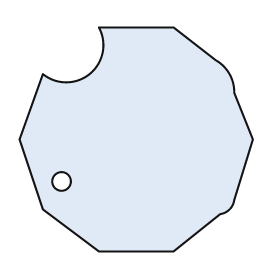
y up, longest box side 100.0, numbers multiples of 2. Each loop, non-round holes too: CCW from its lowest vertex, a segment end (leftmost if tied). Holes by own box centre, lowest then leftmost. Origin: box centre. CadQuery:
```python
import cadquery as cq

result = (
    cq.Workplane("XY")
    .moveTo(-16.0, -48.0)
    .lineTo(16.0, -48.0)
    .lineTo(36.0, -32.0)
    .threePointArc((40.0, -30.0), (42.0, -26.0))
    .lineTo(50.0, 0.0)
    .lineTo(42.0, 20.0)
    .threePointArc((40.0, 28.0), (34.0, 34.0))
    .lineTo(16.0, 48.0)
    .lineTo(-16.0, 48.0)
    .threePointArc((-20.0, 28.0), (-40.0, 28.0))
    .lineTo(-50.0, 0.0)
    .lineTo(-40.0, -30.0)
    .close()
    .moveTo(-32.0, -18.0)
    .circle(4.0)
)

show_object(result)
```